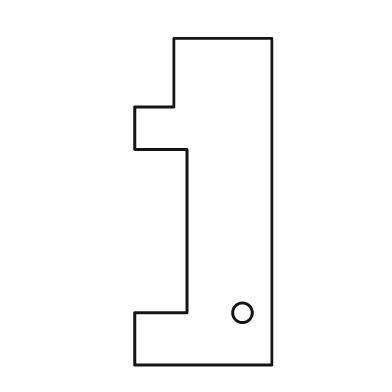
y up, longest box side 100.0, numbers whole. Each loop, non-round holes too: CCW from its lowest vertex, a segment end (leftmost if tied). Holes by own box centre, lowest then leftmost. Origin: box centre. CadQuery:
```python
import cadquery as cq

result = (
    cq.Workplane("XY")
    .moveTo(-21.0, -50.0)
    .lineTo(21.0, -50.0)
    .lineTo(21.0, 50.0)
    .lineTo(-9.0, 50.0)
    .lineTo(-9.0, 29.0)
    .lineTo(-21.0, 29.0)
    .lineTo(-21.0, 16.0)
    .lineTo(-5.0, 16.0)
    .lineTo(-5.0, -34.0)
    .lineTo(-21.0, -34.0)
    .close()
    .moveTo(12.0, -34.0)
    .circle(3.0)
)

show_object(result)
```